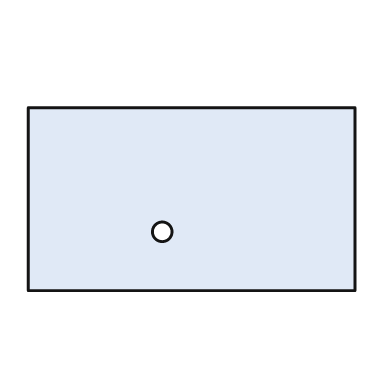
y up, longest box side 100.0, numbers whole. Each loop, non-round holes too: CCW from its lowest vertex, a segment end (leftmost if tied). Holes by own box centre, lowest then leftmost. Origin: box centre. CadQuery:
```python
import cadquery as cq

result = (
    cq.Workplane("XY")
    .moveTo(-50.0, -28.0)
    .lineTo(50.0, -28.0)
    .lineTo(50.0, 28.0)
    .lineTo(-50.0, 28.0)
    .close()
    .moveTo(-9.0, -10.0)
    .circle(3.0)
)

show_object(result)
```